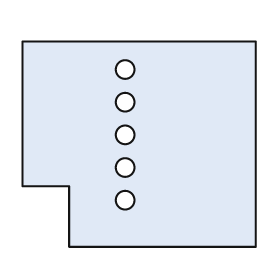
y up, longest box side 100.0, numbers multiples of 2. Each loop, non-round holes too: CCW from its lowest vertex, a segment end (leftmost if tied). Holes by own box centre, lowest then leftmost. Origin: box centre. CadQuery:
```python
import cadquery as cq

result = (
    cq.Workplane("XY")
    .moveTo(-30.0, -44.0)
    .lineTo(50.0, -44.0)
    .lineTo(50.0, 44.0)
    .lineTo(-50.0, 44.0)
    .lineTo(-50.0, -18.0)
    .lineTo(-30.0, -18.0)
    .close()
    .moveTo(-6.0, -24.0)
    .circle(4.0)
    .moveTo(-6.0, -10.0)
    .circle(4.0)
    .moveTo(-6.0, 4.0)
    .circle(4.0)
    .moveTo(-6.0, 18.0)
    .circle(4.0)
    .moveTo(-6.0, 32.0)
    .circle(4.0)
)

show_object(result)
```